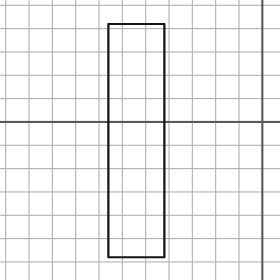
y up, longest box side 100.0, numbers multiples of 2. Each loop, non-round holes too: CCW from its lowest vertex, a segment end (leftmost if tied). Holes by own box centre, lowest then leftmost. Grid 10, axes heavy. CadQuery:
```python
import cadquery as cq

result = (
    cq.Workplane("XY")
    .moveTo(-66.0, -58.0)
    .lineTo(-42.0, -58.0)
    .lineTo(-42.0, 42.0)
    .lineTo(-66.0, 42.0)
    .close()
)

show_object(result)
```